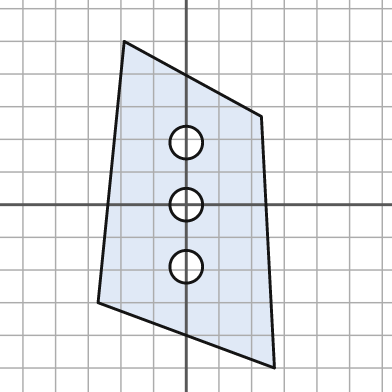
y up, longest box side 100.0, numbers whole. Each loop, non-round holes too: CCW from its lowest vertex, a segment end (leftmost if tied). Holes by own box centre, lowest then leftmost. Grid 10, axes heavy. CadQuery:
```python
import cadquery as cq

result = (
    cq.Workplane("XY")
    .moveTo(27.0, -50.0)
    .lineTo(23.0, 27.0)
    .lineTo(-19.0, 50.0)
    .lineTo(-27.0, -30.0)
    .close()
    .moveTo(0.0, -19.0)
    .circle(5.0)
    .moveTo(0.0, 0.0)
    .circle(5.0)
    .moveTo(0.0, 19.0)
    .circle(5.0)
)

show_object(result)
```